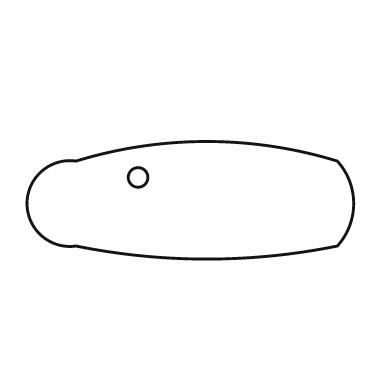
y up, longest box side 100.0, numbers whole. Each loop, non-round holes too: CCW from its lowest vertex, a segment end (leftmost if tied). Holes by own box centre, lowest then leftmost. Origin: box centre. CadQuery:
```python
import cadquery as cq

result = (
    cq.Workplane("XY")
    .moveTo(-35.0, -14.0)
    .threePointArc((5.0, -18.0), (45.0, -14.0))
    .threePointArc((50.0, -1.0), (45.0, 12.0))
    .threePointArc((5.0, 18.0), (-35.0, 12.0))
    .threePointArc((-50.0, -1.0), (-35.0, -14.0))
    .close()
    .moveTo(-16.0, 7.0)
    .circle(3.0)
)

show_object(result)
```